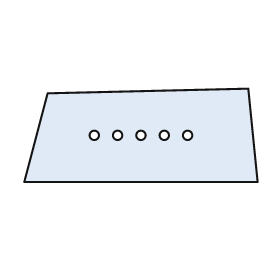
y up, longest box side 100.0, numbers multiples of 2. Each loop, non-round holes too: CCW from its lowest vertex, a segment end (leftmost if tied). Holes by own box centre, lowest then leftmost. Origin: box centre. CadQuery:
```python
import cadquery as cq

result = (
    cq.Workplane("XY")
    .moveTo(-50.0, -20.0)
    .lineTo(50.0, -20.0)
    .lineTo(46.0, 20.0)
    .lineTo(-40.0, 18.0)
    .close()
    .moveTo(-20.0, 0.0)
    .circle(2.0)
    .moveTo(-10.0, 0.0)
    .circle(2.0)
    .moveTo(0.0, 0.0)
    .circle(2.0)
    .moveTo(10.0, 0.0)
    .circle(2.0)
    .moveTo(20.0, 0.0)
    .circle(2.0)
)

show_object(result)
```